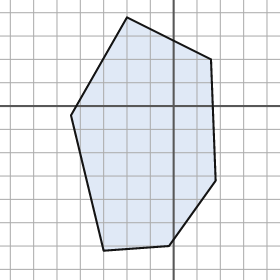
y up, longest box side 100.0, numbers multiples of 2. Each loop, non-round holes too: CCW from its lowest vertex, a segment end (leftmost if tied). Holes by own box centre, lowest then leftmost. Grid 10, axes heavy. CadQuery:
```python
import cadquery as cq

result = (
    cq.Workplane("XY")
    .moveTo(-30.0, -62.0)
    .lineTo(-2.0, -60.0)
    .lineTo(18.0, -32.0)
    .lineTo(16.0, 20.0)
    .lineTo(-20.0, 38.0)
    .lineTo(-44.0, -4.0)
    .close()
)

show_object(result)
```